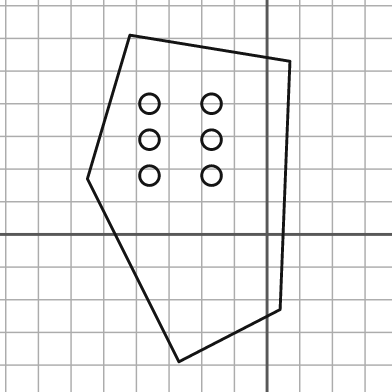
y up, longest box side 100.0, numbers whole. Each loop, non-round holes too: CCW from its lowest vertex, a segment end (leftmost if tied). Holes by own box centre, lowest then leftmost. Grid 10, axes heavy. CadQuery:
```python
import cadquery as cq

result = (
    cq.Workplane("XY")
    .moveTo(-27.0, -39.0)
    .lineTo(4.0, -23.0)
    .lineTo(7.0, 53.0)
    .lineTo(-42.0, 61.0)
    .lineTo(-55.0, 17.0)
    .close()
    .moveTo(-36.0, 18.0)
    .circle(3.0)
    .moveTo(-17.0, 18.0)
    .circle(3.0)
    .moveTo(-36.0, 29.0)
    .circle(3.0)
    .moveTo(-17.0, 29.0)
    .circle(3.0)
    .moveTo(-36.0, 40.0)
    .circle(3.0)
    .moveTo(-17.0, 40.0)
    .circle(3.0)
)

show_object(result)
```